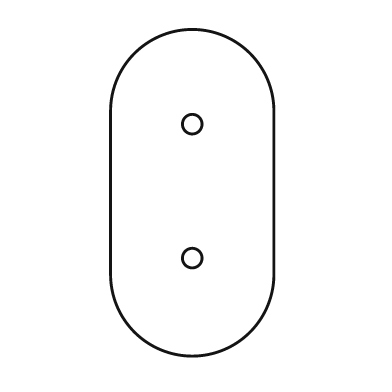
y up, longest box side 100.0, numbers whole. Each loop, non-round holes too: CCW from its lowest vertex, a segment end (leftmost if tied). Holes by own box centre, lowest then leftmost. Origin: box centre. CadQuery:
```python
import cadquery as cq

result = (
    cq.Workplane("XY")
    .moveTo(-25.0, -25.0)
    .threePointArc((0.0, -50.0), (25.0, -25.0))
    .lineTo(25.0, 25.0)
    .threePointArc((0.0, 50.0), (-25.0, 25.0))
    .close()
    .moveTo(0.0, -20.0)
    .circle(3.0)
    .moveTo(0.0, 21.0)
    .circle(3.0)
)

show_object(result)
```